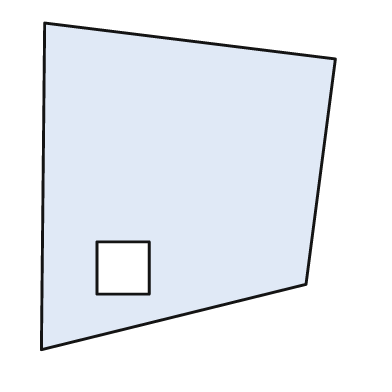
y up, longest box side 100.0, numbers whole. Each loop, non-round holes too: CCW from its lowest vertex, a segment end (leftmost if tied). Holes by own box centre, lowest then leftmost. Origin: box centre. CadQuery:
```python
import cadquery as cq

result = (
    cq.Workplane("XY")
    .moveTo(-45.0, -50.0)
    .lineTo(36.0, -30.0)
    .lineTo(45.0, 39.0)
    .lineTo(-44.0, 50.0)
    .close()
    .moveTo(-28.0, -33.0)
    .lineTo(-12.0, -33.0)
    .lineTo(-12.0, -17.0)
    .lineTo(-28.0, -17.0)
    .close()
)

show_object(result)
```